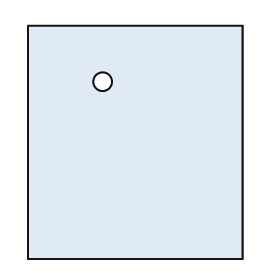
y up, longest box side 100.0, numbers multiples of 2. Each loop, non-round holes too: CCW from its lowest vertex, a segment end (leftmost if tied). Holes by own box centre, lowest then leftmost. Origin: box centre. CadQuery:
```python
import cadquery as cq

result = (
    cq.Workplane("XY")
    .moveTo(-46.0, -50.0)
    .lineTo(46.0, -50.0)
    .lineTo(46.0, 50.0)
    .lineTo(-46.0, 50.0)
    .close()
    .moveTo(-14.0, 26.0)
    .circle(4.0)
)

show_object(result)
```